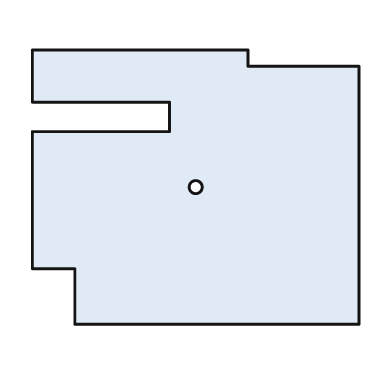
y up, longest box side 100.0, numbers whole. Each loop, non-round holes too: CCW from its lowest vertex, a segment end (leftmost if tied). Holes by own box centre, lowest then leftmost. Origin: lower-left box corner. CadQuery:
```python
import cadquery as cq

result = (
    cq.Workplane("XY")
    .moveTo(13.0, 0.0)
    .lineTo(100.0, 0.0)
    .lineTo(100.0, 79.0)
    .lineTo(66.0, 79.0)
    .lineTo(66.0, 84.0)
    .lineTo(0.0, 84.0)
    .lineTo(0.0, 68.0)
    .lineTo(42.0, 68.0)
    .lineTo(42.0, 59.0)
    .lineTo(0.0, 59.0)
    .lineTo(0.0, 17.0)
    .lineTo(13.0, 17.0)
    .close()
    .moveTo(50.0, 42.0)
    .circle(2.0)
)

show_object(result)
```